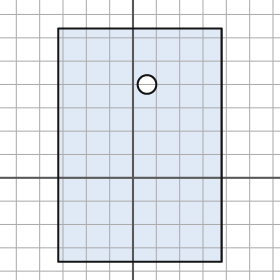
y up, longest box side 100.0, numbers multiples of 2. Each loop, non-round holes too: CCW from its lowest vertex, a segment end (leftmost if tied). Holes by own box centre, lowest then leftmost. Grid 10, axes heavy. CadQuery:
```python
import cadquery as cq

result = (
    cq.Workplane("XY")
    .moveTo(-32.0, -36.0)
    .lineTo(38.0, -36.0)
    .lineTo(38.0, 64.0)
    .lineTo(-32.0, 64.0)
    .close()
    .moveTo(6.0, 40.0)
    .circle(4.0)
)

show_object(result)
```